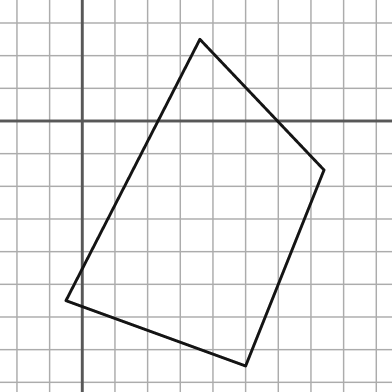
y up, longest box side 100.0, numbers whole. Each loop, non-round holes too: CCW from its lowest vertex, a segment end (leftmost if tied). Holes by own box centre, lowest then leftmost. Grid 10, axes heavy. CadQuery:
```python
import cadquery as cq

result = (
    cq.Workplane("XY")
    .moveTo(50.0, -75.0)
    .lineTo(74.0, -15.0)
    .lineTo(36.0, 25.0)
    .lineTo(-5.0, -55.0)
    .close()
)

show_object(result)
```